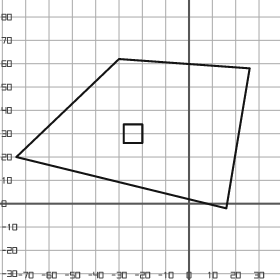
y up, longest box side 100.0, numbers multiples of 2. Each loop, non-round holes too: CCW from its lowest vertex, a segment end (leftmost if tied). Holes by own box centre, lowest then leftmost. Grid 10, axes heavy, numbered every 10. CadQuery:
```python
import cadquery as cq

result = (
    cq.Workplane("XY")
    .moveTo(16.0, -2.0)
    .lineTo(26.0, 58.0)
    .lineTo(-30.0, 62.0)
    .lineTo(-74.0, 20.0)
    .close()
    .moveTo(-28.0, 26.0)
    .lineTo(-20.0, 26.0)
    .lineTo(-20.0, 34.0)
    .lineTo(-28.0, 34.0)
    .close()
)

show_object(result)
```